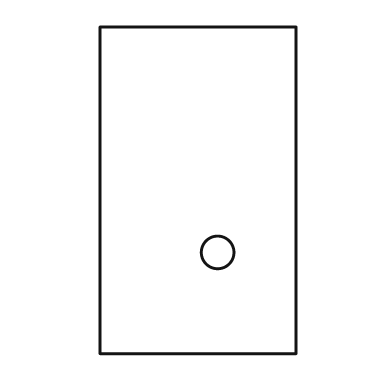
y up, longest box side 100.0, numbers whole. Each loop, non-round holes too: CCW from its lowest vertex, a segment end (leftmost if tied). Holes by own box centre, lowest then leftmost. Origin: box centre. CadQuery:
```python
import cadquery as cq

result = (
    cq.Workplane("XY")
    .moveTo(-30.0, -50.0)
    .lineTo(30.0, -50.0)
    .lineTo(30.0, 50.0)
    .lineTo(-30.0, 50.0)
    .close()
    .moveTo(6.0, -19.0)
    .circle(5.0)
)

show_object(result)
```